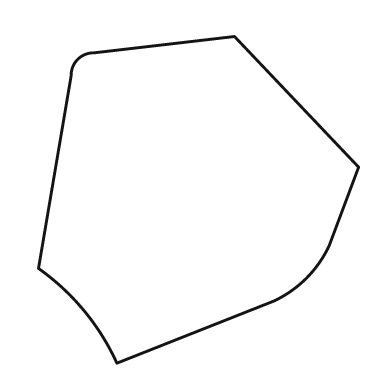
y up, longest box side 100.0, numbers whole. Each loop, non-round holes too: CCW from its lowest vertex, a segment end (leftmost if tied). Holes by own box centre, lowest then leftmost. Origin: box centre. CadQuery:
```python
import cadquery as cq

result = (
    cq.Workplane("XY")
    .moveTo(-25.0, -50.0)
    .lineTo(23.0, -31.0)
    .threePointArc((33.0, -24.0), (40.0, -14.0))
    .lineTo(49.0, 10.0)
    .lineTo(11.0, 50.0)
    .lineTo(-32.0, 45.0)
    .threePointArc((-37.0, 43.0), (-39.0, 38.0))
    .lineTo(-49.0, -21.0)
    .threePointArc((-35.0, -34.0), (-25.0, -50.0))
    .close()
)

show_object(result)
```